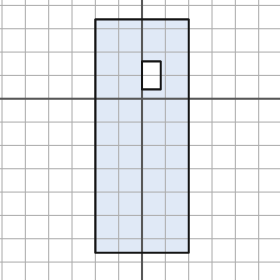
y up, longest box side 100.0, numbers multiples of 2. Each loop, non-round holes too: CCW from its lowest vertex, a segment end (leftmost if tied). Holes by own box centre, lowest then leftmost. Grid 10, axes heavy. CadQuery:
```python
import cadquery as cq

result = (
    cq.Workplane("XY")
    .moveTo(-20.0, -66.0)
    .lineTo(20.0, -66.0)
    .lineTo(20.0, 34.0)
    .lineTo(-20.0, 34.0)
    .close()
    .moveTo(0.0, 4.0)
    .lineTo(8.0, 4.0)
    .lineTo(8.0, 16.0)
    .lineTo(0.0, 16.0)
    .close()
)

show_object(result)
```